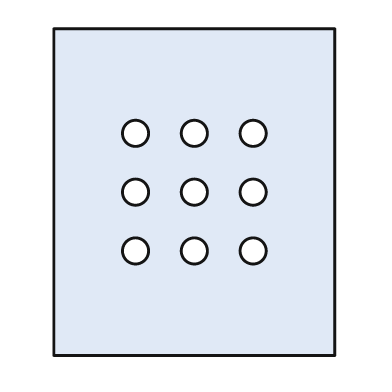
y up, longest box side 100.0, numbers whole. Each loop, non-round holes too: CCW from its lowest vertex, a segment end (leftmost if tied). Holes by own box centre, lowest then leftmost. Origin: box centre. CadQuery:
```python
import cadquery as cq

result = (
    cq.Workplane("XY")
    .moveTo(-43.0, -50.0)
    .lineTo(43.0, -50.0)
    .lineTo(43.0, 50.0)
    .lineTo(-43.0, 50.0)
    .close()
    .moveTo(-18.0, -18.0)
    .circle(4.0)
    .moveTo(0.0, -18.0)
    .circle(4.0)
    .moveTo(18.0, -18.0)
    .circle(4.0)
    .moveTo(-18.0, 0.0)
    .circle(4.0)
    .moveTo(0.0, 0.0)
    .circle(4.0)
    .moveTo(18.0, 0.0)
    .circle(4.0)
    .moveTo(-18.0, 18.0)
    .circle(4.0)
    .moveTo(0.0, 18.0)
    .circle(4.0)
    .moveTo(18.0, 18.0)
    .circle(4.0)
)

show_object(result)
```